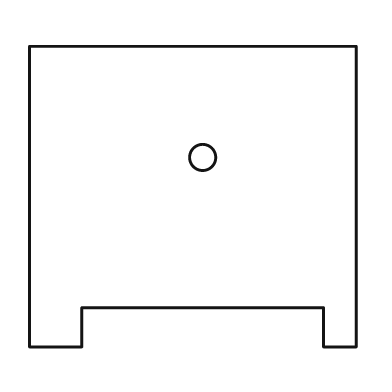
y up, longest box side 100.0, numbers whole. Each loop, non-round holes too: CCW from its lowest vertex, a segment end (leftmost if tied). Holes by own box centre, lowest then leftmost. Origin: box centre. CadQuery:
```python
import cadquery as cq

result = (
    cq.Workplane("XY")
    .moveTo(-50.0, -46.0)
    .lineTo(-34.0, -46.0)
    .lineTo(-34.0, -34.0)
    .lineTo(40.0, -34.0)
    .lineTo(40.0, -46.0)
    .lineTo(50.0, -46.0)
    .lineTo(50.0, 46.0)
    .lineTo(-50.0, 46.0)
    .close()
    .moveTo(3.0, 12.0)
    .circle(4.0)
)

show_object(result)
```